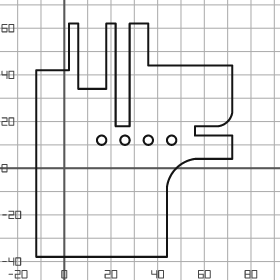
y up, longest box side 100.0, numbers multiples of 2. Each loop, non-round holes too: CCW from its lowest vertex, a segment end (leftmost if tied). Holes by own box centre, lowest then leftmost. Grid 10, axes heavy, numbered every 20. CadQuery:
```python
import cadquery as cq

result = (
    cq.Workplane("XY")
    .moveTo(-12.0, -38.0)
    .lineTo(44.0, -38.0)
    .lineTo(44.0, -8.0)
    .threePointArc((48.0, 0.0), (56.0, 4.0))
    .lineTo(72.0, 4.0)
    .lineTo(72.0, 14.0)
    .lineTo(56.0, 14.0)
    .lineTo(56.0, 18.0)
    .lineTo(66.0, 18.0)
    .threePointArc((70.0, 20.0), (72.0, 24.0))
    .lineTo(72.0, 44.0)
    .lineTo(36.0, 44.0)
    .lineTo(36.0, 62.0)
    .lineTo(28.0, 62.0)
    .lineTo(28.0, 18.0)
    .lineTo(22.0, 18.0)
    .lineTo(22.0, 62.0)
    .lineTo(18.0, 62.0)
    .lineTo(18.0, 34.0)
    .lineTo(6.0, 34.0)
    .lineTo(6.0, 62.0)
    .lineTo(2.0, 62.0)
    .lineTo(2.0, 42.0)
    .lineTo(-12.0, 42.0)
    .close()
    .moveTo(16.0, 12.0)
    .circle(2.0)
    .moveTo(26.0, 12.0)
    .circle(2.0)
    .moveTo(36.0, 12.0)
    .circle(2.0)
    .moveTo(46.0, 12.0)
    .circle(2.0)
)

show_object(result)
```